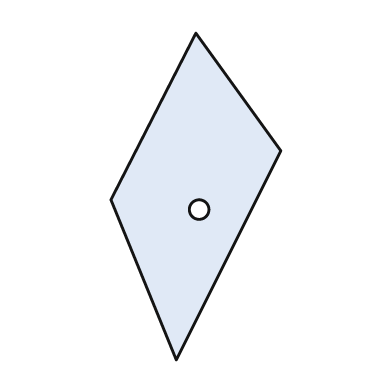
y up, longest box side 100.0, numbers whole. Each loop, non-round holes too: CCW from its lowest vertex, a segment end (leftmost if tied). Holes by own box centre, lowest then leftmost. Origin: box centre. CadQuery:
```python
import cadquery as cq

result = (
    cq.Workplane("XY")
    .moveTo(-6.0, -50.0)
    .lineTo(26.0, 14.0)
    .lineTo(0.0, 50.0)
    .lineTo(-26.0, -1.0)
    .close()
    .moveTo(1.0, -4.0)
    .circle(3.0)
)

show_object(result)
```